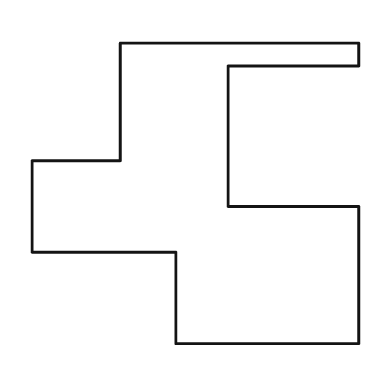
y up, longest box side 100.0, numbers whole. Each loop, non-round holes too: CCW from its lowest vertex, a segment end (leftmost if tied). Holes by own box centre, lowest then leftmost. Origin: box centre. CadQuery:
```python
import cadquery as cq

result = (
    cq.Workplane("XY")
    .moveTo(-6.0, -46.0)
    .lineTo(50.0, -46.0)
    .lineTo(50.0, -4.0)
    .lineTo(10.0, -4.0)
    .lineTo(10.0, 39.0)
    .lineTo(50.0, 39.0)
    .lineTo(50.0, 46.0)
    .lineTo(-23.0, 46.0)
    .lineTo(-23.0, 10.0)
    .lineTo(-50.0, 10.0)
    .lineTo(-50.0, -18.0)
    .lineTo(-6.0, -18.0)
    .close()
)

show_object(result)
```